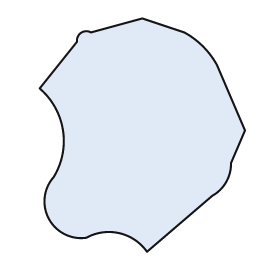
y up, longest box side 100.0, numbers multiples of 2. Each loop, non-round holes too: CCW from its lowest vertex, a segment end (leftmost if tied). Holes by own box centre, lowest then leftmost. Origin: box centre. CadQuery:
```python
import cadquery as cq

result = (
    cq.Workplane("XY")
    .moveTo(2.0, -50.0)
    .lineTo(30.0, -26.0)
    .threePointArc((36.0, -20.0), (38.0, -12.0))
    .lineTo(44.0, 2.0)
    .lineTo(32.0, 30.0)
    .threePointArc((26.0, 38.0), (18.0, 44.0))
    .lineTo(0.0, 50.0)
    .lineTo(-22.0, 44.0)
    .threePointArc((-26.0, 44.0), (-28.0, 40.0))
    .lineTo(-44.0, 20.0)
    .threePointArc((-34.0, 2.0), (-38.0, -18.0))
    .threePointArc((-40.0, -36.0), (-24.0, -44.0))
    .threePointArc((-10.0, -42.0), (2.0, -50.0))
    .close()
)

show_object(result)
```